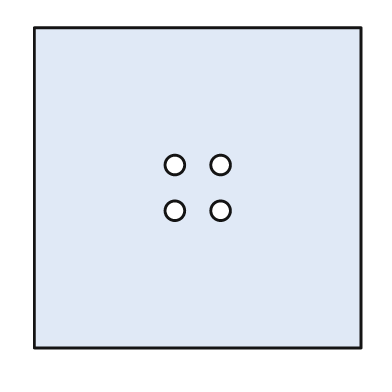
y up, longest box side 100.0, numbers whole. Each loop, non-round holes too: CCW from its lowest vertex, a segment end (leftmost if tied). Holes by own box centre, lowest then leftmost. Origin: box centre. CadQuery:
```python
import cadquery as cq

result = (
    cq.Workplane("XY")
    .moveTo(-50.0, -49.0)
    .lineTo(50.0, -49.0)
    .lineTo(50.0, 49.0)
    .lineTo(-50.0, 49.0)
    .close()
    .moveTo(-7.0, -7.0)
    .circle(3.0)
    .moveTo(7.0, -7.0)
    .circle(3.0)
    .moveTo(-7.0, 7.0)
    .circle(3.0)
    .moveTo(7.0, 7.0)
    .circle(3.0)
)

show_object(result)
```